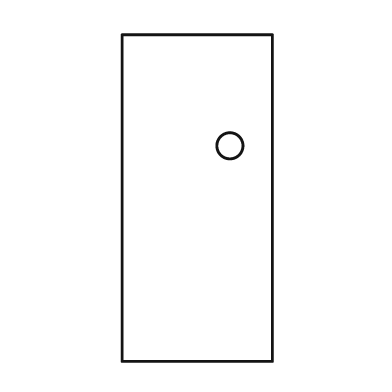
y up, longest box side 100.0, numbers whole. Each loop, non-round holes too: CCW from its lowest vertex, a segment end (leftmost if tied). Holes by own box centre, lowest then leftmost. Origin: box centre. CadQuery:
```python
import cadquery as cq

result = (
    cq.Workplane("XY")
    .moveTo(-23.0, -50.0)
    .lineTo(23.0, -50.0)
    .lineTo(23.0, 50.0)
    .lineTo(-23.0, 50.0)
    .close()
    .moveTo(10.0, 16.0)
    .circle(4.0)
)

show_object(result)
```